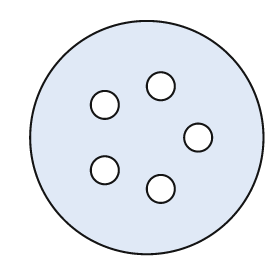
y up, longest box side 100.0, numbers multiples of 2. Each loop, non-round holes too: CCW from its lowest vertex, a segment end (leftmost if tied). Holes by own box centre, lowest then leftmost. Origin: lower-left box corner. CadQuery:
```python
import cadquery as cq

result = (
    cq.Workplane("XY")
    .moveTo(50.0, 50.0)
    .circle(50.0)
    .moveTo(56.0, 28.0)
    .circle(6.0)
    .moveTo(32.0, 36.0)
    .circle(6.0)
    .moveTo(72.0, 50.0)
    .circle(6.0)
    .moveTo(32.0, 64.0)
    .circle(6.0)
    .moveTo(56.0, 72.0)
    .circle(6.0)
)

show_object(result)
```